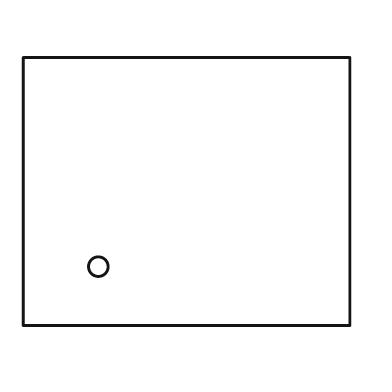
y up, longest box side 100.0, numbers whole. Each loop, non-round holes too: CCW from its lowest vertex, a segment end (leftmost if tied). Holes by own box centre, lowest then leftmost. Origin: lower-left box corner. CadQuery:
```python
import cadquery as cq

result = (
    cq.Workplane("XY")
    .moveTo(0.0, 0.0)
    .lineTo(100.0, 0.0)
    .lineTo(100.0, 82.0)
    .lineTo(0.0, 82.0)
    .close()
    .moveTo(23.0, 18.0)
    .circle(3.0)
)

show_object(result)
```